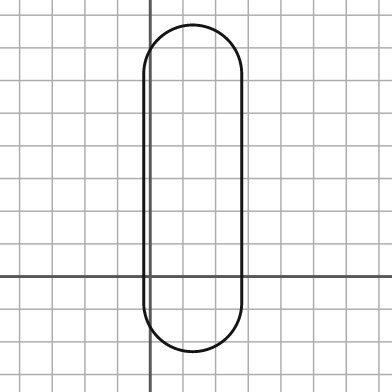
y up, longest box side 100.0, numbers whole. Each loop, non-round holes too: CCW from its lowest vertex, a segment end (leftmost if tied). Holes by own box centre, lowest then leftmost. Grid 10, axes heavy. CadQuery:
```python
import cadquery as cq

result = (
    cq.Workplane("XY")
    .moveTo(-2.0, -8.0)
    .threePointArc((13.0, -23.0), (28.0, -8.0))
    .lineTo(28.0, 62.0)
    .threePointArc((13.0, 77.0), (-2.0, 62.0))
    .close()
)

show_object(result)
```